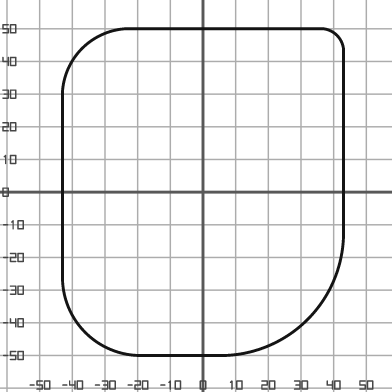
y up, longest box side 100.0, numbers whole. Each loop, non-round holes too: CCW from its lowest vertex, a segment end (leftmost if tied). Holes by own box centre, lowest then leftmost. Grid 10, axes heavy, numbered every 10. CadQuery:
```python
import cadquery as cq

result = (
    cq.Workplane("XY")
    .moveTo(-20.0, -50.0)
    .lineTo(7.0, -50.0)
    .threePointArc((32.0, -39.0), (43.0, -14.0))
    .lineTo(43.0, 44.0)
    .threePointArc((41.0, 48.0), (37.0, 50.0))
    .lineTo(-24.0, 50.0)
    .threePointArc((-37.0, 44.0), (-43.0, 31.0))
    .lineTo(-43.0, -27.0)
    .threePointArc((-36.0, -43.0), (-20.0, -50.0))
    .close()
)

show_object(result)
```